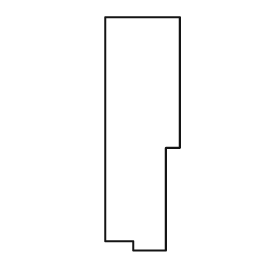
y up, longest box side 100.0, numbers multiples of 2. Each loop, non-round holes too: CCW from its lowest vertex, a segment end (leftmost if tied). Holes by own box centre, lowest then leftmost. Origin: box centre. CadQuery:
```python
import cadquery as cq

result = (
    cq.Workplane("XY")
    .moveTo(-4.0, -50.0)
    .lineTo(10.0, -50.0)
    .lineTo(10.0, -6.0)
    .lineTo(16.0, -6.0)
    .lineTo(16.0, 50.0)
    .lineTo(-16.0, 50.0)
    .lineTo(-16.0, -46.0)
    .lineTo(-4.0, -46.0)
    .close()
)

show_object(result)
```